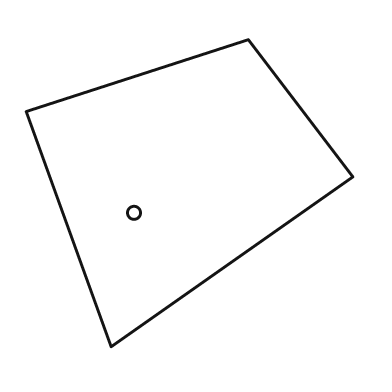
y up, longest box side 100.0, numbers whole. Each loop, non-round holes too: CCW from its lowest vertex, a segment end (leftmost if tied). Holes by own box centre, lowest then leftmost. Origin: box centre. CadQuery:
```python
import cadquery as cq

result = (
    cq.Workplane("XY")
    .moveTo(-24.0, -47.0)
    .lineTo(50.0, 5.0)
    .lineTo(18.0, 47.0)
    .lineTo(-50.0, 25.0)
    .close()
    .moveTo(-17.0, -6.0)
    .circle(2.0)
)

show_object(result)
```